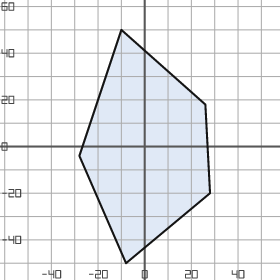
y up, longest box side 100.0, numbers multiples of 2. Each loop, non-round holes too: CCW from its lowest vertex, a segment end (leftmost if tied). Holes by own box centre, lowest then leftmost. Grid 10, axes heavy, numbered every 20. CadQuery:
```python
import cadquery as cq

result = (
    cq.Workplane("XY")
    .moveTo(-8.0, -50.0)
    .lineTo(28.0, -20.0)
    .lineTo(26.0, 18.0)
    .lineTo(-10.0, 50.0)
    .lineTo(-28.0, -4.0)
    .close()
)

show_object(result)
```